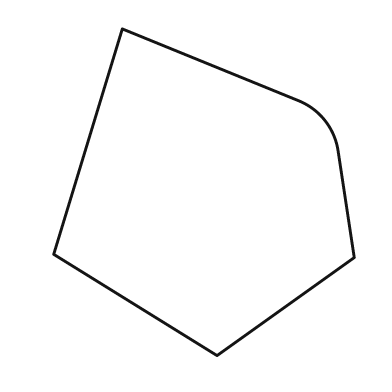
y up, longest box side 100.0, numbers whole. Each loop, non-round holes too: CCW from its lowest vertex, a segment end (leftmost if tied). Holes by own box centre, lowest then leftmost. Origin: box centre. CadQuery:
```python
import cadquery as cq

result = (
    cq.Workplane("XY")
    .moveTo(4.0, -50.0)
    .lineTo(46.0, -20.0)
    .lineTo(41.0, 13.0)
    .threePointArc((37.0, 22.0), (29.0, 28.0))
    .lineTo(-25.0, 50.0)
    .lineTo(-46.0, -19.0)
    .close()
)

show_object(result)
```